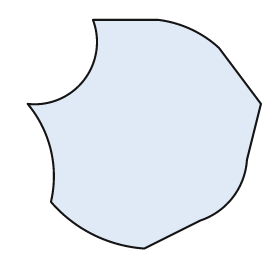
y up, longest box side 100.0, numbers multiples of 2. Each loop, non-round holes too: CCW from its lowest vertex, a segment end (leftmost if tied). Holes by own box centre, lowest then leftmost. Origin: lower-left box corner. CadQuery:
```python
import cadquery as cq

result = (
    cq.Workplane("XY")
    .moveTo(50.0, 0.0)
    .lineTo(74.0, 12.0)
    .threePointArc((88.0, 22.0), (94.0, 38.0))
    .lineTo(100.0, 62.0)
    .lineTo(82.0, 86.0)
    .threePointArc((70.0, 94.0), (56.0, 98.0))
    .lineTo(28.0, 98.0)
    .threePointArc((24.0, 72.0), (0.0, 62.0))
    .threePointArc((10.0, 42.0), (10.0, 20.0))
    .threePointArc((28.0, 6.0), (50.0, 0.0))
    .close()
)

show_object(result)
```